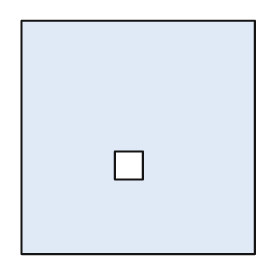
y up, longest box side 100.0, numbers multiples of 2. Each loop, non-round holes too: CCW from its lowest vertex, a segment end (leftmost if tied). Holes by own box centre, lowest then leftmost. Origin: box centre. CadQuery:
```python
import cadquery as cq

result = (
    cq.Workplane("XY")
    .moveTo(-50.0, -50.0)
    .lineTo(50.0, -50.0)
    .lineTo(50.0, 50.0)
    .lineTo(-50.0, 50.0)
    .close()
    .moveTo(-10.0, -18.0)
    .lineTo(2.0, -18.0)
    .lineTo(2.0, -6.0)
    .lineTo(-10.0, -6.0)
    .close()
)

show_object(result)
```